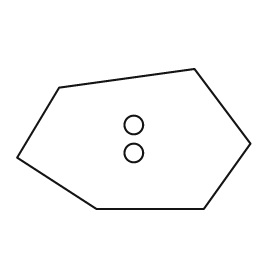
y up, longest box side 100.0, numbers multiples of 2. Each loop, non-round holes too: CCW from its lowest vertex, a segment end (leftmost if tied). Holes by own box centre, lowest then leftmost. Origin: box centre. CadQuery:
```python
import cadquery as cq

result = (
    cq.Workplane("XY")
    .moveTo(-16.0, -30.0)
    .lineTo(30.0, -30.0)
    .lineTo(50.0, -2.0)
    .lineTo(26.0, 30.0)
    .lineTo(-32.0, 22.0)
    .lineTo(-50.0, -8.0)
    .close()
    .moveTo(0.0, -6.0)
    .circle(4.0)
    .moveTo(0.0, 6.0)
    .circle(4.0)
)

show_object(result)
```